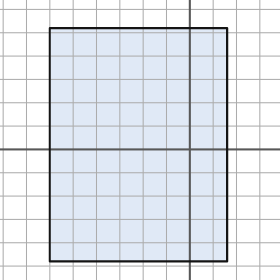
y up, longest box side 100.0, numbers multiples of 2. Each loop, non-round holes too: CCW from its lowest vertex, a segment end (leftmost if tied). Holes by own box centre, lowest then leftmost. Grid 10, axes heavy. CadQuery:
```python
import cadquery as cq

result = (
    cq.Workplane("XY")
    .moveTo(-60.0, -48.0)
    .lineTo(16.0, -48.0)
    .lineTo(16.0, 52.0)
    .lineTo(-60.0, 52.0)
    .close()
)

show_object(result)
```